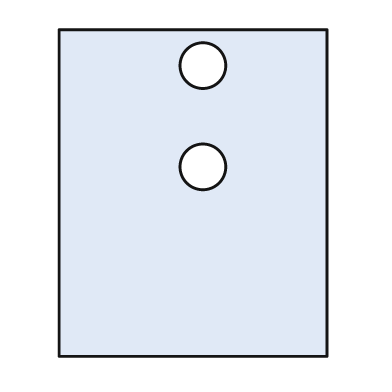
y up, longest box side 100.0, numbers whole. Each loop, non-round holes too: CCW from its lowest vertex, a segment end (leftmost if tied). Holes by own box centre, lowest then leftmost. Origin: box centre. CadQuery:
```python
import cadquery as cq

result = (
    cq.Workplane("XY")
    .moveTo(-41.0, -50.0)
    .lineTo(41.0, -50.0)
    .lineTo(41.0, 50.0)
    .lineTo(-41.0, 50.0)
    .close()
    .moveTo(3.0, 8.0)
    .circle(7.0)
    .moveTo(3.0, 39.0)
    .circle(7.0)
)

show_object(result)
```